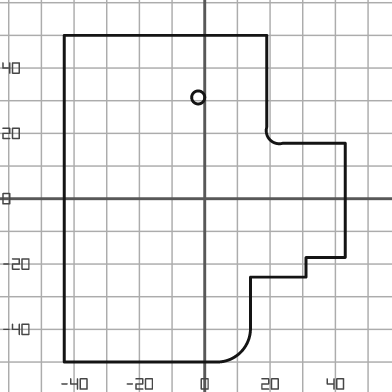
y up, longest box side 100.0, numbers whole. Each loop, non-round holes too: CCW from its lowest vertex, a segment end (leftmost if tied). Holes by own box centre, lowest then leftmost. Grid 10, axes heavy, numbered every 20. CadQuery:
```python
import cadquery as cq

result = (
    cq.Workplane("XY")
    .moveTo(-43.0, -50.0)
    .lineTo(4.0, -50.0)
    .threePointArc((11.0, -47.0), (14.0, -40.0))
    .lineTo(14.0, -24.0)
    .lineTo(31.0, -24.0)
    .lineTo(31.0, -18.0)
    .lineTo(43.0, -18.0)
    .lineTo(43.0, 17.0)
    .lineTo(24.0, 17.0)
    .threePointArc((20.0, 18.0), (19.0, 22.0))
    .lineTo(19.0, 50.0)
    .lineTo(-43.0, 50.0)
    .close()
    .moveTo(-2.0, 31.0)
    .circle(2.0)
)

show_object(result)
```